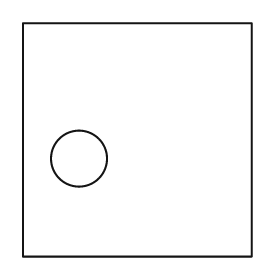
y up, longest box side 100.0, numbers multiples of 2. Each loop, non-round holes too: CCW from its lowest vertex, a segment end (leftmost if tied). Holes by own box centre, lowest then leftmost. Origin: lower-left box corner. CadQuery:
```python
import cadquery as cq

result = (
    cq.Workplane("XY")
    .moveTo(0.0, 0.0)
    .lineTo(98.0, 0.0)
    .lineTo(98.0, 100.0)
    .lineTo(0.0, 100.0)
    .close()
    .moveTo(24.0, 42.0)
    .circle(12.0)
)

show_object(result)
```